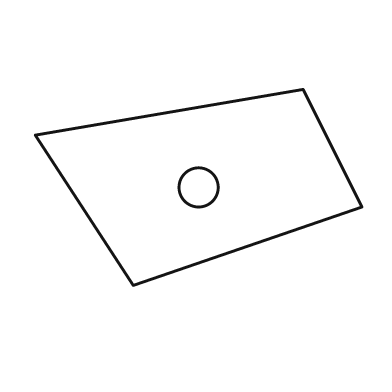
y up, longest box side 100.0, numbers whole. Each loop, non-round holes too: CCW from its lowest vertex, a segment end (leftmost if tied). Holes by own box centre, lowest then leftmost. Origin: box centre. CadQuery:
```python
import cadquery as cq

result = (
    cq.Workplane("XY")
    .moveTo(-20.0, -30.0)
    .lineTo(50.0, -6.0)
    .lineTo(32.0, 30.0)
    .lineTo(-50.0, 16.0)
    .close()
    .moveTo(0.0, 0.0)
    .circle(6.0)
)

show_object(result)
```